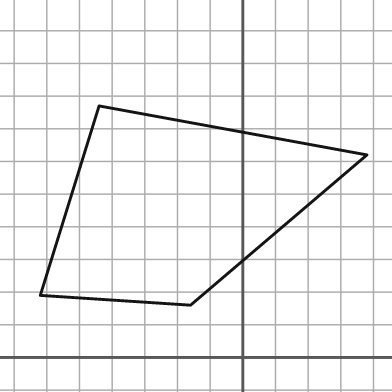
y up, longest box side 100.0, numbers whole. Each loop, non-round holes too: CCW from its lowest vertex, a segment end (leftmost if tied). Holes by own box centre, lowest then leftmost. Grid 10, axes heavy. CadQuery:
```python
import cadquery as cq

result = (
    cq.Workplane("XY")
    .moveTo(-16.0, 16.0)
    .lineTo(38.0, 62.0)
    .lineTo(-44.0, 77.0)
    .lineTo(-62.0, 19.0)
    .close()
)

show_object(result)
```